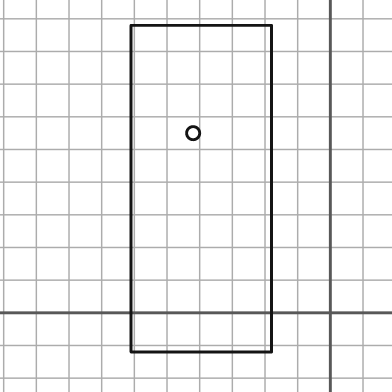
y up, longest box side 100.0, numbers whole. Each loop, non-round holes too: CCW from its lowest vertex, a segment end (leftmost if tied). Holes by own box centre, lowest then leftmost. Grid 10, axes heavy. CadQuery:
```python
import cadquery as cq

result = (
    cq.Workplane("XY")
    .moveTo(-61.0, -12.0)
    .lineTo(-18.0, -12.0)
    .lineTo(-18.0, 88.0)
    .lineTo(-61.0, 88.0)
    .close()
    .moveTo(-42.0, 55.0)
    .circle(2.0)
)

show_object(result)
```